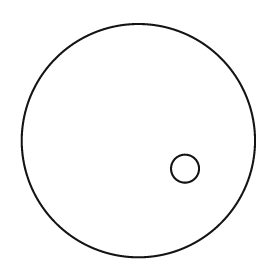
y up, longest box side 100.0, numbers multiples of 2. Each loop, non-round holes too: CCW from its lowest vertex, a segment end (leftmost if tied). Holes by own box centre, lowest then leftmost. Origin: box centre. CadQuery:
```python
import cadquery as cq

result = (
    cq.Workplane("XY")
    .moveTo(0.0, 0.0)
    .circle(50.0)
    .moveTo(20.0, -12.0)
    .circle(6.0)
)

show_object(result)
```